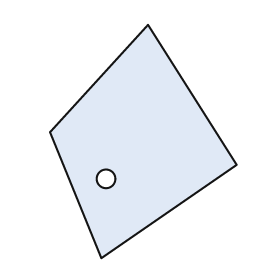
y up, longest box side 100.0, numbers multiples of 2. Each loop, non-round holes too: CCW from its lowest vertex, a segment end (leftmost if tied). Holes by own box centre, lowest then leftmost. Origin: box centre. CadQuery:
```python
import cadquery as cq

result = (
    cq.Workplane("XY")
    .moveTo(-18.0, -50.0)
    .lineTo(40.0, -10.0)
    .lineTo(2.0, 50.0)
    .lineTo(-40.0, 4.0)
    .close()
    .moveTo(-16.0, -16.0)
    .circle(4.0)
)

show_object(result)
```